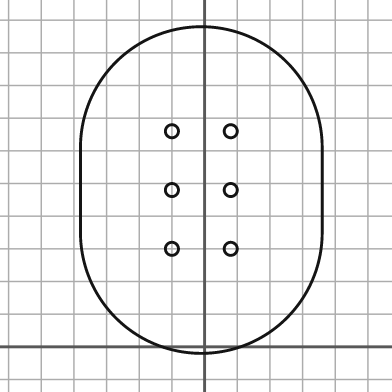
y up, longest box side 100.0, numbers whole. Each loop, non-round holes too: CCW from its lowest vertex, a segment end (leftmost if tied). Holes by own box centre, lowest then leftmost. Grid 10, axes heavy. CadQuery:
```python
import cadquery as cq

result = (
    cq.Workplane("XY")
    .moveTo(-38.0, 35.0)
    .threePointArc((-1.0, -2.0), (36.0, 35.0))
    .lineTo(36.0, 61.0)
    .threePointArc((-1.0, 98.0), (-38.0, 61.0))
    .close()
    .moveTo(-10.0, 30.0)
    .circle(2.0)
    .moveTo(8.0, 30.0)
    .circle(2.0)
    .moveTo(-10.0, 48.0)
    .circle(2.0)
    .moveTo(8.0, 48.0)
    .circle(2.0)
    .moveTo(-10.0, 66.0)
    .circle(2.0)
    .moveTo(8.0, 66.0)
    .circle(2.0)
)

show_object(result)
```